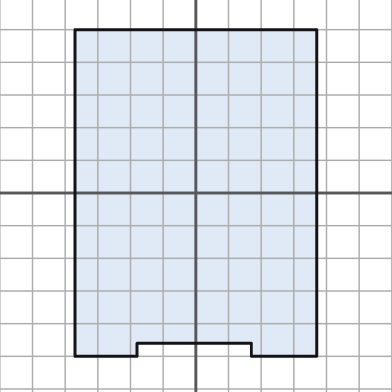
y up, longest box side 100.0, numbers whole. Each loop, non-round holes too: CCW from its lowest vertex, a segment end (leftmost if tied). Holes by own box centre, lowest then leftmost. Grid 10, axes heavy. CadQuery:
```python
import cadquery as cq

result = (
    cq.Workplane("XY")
    .moveTo(-37.0, -50.0)
    .lineTo(-18.0, -50.0)
    .lineTo(-18.0, -46.0)
    .lineTo(17.0, -46.0)
    .lineTo(17.0, -50.0)
    .lineTo(37.0, -50.0)
    .lineTo(37.0, 50.0)
    .lineTo(-37.0, 50.0)
    .close()
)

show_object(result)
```